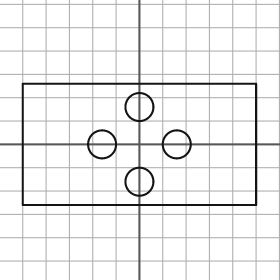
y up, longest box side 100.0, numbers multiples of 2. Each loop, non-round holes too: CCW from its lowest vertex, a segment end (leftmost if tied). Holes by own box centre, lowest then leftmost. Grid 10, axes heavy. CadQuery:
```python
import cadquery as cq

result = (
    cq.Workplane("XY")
    .moveTo(-50.0, -26.0)
    .lineTo(50.0, -26.0)
    .lineTo(50.0, 26.0)
    .lineTo(-50.0, 26.0)
    .close()
    .moveTo(0.0, -16.0)
    .circle(6.0)
    .moveTo(-16.0, 0.0)
    .circle(6.0)
    .moveTo(16.0, 0.0)
    .circle(6.0)
    .moveTo(0.0, 16.0)
    .circle(6.0)
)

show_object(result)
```